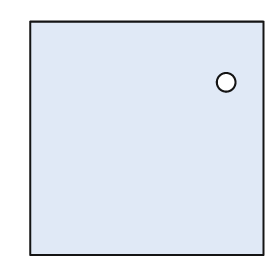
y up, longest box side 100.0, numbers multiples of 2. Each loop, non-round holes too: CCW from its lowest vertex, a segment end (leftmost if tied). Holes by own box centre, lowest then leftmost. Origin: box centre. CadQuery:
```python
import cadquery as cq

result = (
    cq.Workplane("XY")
    .moveTo(-50.0, -50.0)
    .lineTo(50.0, -50.0)
    .lineTo(50.0, 50.0)
    .lineTo(-50.0, 50.0)
    .close()
    .moveTo(34.0, 24.0)
    .circle(4.0)
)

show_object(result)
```